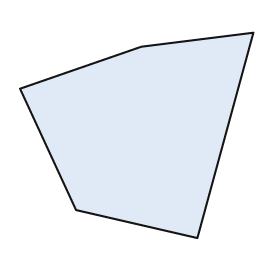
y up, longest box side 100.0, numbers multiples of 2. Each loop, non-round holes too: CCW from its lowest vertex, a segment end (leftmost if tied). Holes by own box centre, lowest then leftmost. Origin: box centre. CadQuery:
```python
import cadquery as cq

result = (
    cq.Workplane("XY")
    .moveTo(26.0, -44.0)
    .lineTo(50.0, 44.0)
    .lineTo(2.0, 38.0)
    .lineTo(-50.0, 20.0)
    .lineTo(-26.0, -32.0)
    .close()
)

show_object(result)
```